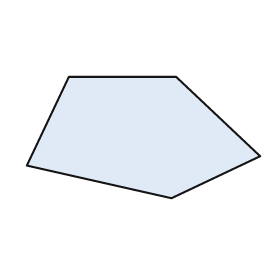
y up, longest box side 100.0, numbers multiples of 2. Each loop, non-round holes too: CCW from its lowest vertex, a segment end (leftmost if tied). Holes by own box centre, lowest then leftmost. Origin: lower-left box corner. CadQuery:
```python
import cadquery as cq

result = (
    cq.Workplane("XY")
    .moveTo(62.0, 0.0)
    .lineTo(100.0, 18.0)
    .lineTo(64.0, 52.0)
    .lineTo(18.0, 52.0)
    .lineTo(0.0, 14.0)
    .close()
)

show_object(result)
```